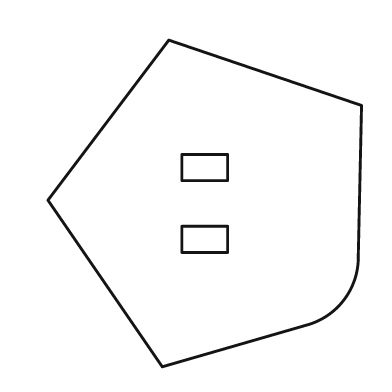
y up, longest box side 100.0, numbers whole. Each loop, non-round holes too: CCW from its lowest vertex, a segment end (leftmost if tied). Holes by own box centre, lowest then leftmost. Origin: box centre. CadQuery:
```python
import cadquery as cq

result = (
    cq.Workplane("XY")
    .moveTo(-13.0, -50.0)
    .lineTo(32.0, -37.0)
    .threePointArc((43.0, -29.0), (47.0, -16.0))
    .lineTo(48.0, 30.0)
    .lineTo(-11.0, 50.0)
    .lineTo(-48.0, 1.0)
    .close()
    .moveTo(-7.0, -15.0)
    .lineTo(7.0, -15.0)
    .lineTo(7.0, -7.0)
    .lineTo(-7.0, -7.0)
    .close()
    .moveTo(-7.0, 7.0)
    .lineTo(7.0, 7.0)
    .lineTo(7.0, 15.0)
    .lineTo(-7.0, 15.0)
    .close()
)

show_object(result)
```